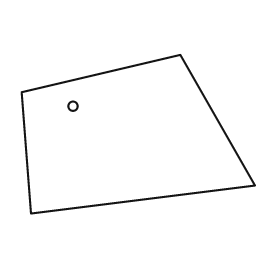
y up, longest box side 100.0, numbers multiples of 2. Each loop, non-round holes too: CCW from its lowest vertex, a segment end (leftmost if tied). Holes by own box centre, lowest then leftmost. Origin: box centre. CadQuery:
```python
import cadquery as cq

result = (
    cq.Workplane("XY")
    .moveTo(-46.0, -34.0)
    .lineTo(50.0, -22.0)
    .lineTo(18.0, 34.0)
    .lineTo(-50.0, 18.0)
    .close()
    .moveTo(-28.0, 12.0)
    .circle(2.0)
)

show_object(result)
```